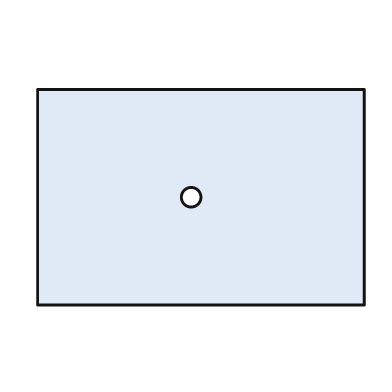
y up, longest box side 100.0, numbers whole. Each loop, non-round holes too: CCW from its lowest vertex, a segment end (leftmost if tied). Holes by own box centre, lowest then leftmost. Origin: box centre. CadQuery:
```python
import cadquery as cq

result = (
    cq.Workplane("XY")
    .moveTo(-50.0, -33.0)
    .lineTo(50.0, -33.0)
    .lineTo(50.0, 33.0)
    .lineTo(-50.0, 33.0)
    .close()
    .moveTo(-3.0, 0.0)
    .circle(3.0)
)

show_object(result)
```